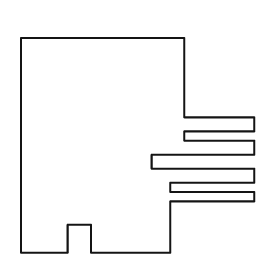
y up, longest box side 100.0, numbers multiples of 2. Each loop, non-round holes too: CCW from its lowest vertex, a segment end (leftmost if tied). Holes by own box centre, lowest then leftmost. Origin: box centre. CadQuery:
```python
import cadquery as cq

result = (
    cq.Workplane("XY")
    .moveTo(-50.0, -46.0)
    .lineTo(-30.0, -46.0)
    .lineTo(-30.0, -34.0)
    .lineTo(-20.0, -34.0)
    .lineTo(-20.0, -46.0)
    .lineTo(14.0, -46.0)
    .lineTo(14.0, -24.0)
    .lineTo(50.0, -24.0)
    .lineTo(50.0, -20.0)
    .lineTo(14.0, -20.0)
    .lineTo(14.0, -16.0)
    .lineTo(50.0, -16.0)
    .lineTo(50.0, -10.0)
    .lineTo(6.0, -10.0)
    .lineTo(6.0, -4.0)
    .lineTo(50.0, -4.0)
    .lineTo(50.0, 2.0)
    .lineTo(20.0, 2.0)
    .lineTo(20.0, 6.0)
    .lineTo(50.0, 6.0)
    .lineTo(50.0, 12.0)
    .lineTo(20.0, 12.0)
    .lineTo(20.0, 46.0)
    .lineTo(-50.0, 46.0)
    .close()
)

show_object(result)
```